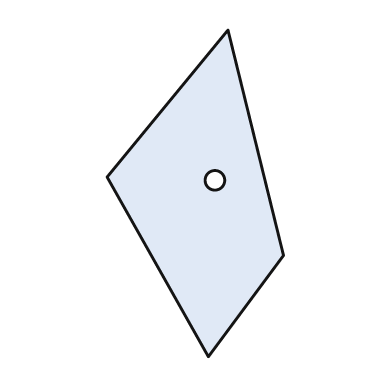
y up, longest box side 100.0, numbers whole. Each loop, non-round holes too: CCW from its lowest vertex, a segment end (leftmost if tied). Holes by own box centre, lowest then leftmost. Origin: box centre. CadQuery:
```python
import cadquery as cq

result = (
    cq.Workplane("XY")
    .moveTo(4.0, -50.0)
    .lineTo(27.0, -19.0)
    .lineTo(10.0, 50.0)
    .lineTo(-27.0, 5.0)
    .close()
    .moveTo(6.0, 4.0)
    .circle(3.0)
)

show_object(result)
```